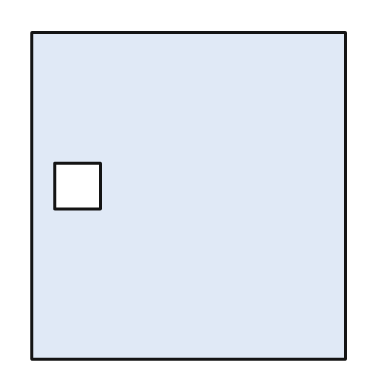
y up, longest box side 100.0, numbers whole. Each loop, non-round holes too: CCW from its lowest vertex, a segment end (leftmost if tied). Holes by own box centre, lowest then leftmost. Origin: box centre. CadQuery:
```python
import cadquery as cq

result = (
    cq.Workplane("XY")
    .moveTo(-48.0, -50.0)
    .lineTo(48.0, -50.0)
    .lineTo(48.0, 50.0)
    .lineTo(-48.0, 50.0)
    .close()
    .moveTo(-41.0, -4.0)
    .lineTo(-27.0, -4.0)
    .lineTo(-27.0, 10.0)
    .lineTo(-41.0, 10.0)
    .close()
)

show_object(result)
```